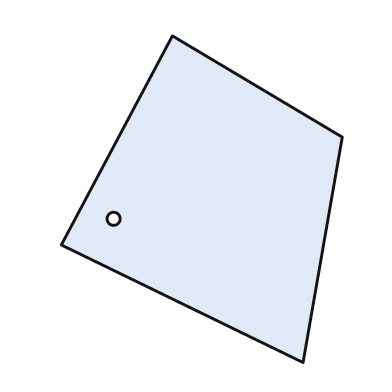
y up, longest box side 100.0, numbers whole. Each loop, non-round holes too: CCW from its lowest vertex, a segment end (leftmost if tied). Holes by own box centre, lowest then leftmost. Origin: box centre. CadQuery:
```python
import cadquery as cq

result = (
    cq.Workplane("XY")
    .moveTo(31.0, -50.0)
    .lineTo(43.0, 19.0)
    .lineTo(-9.0, 50.0)
    .lineTo(-43.0, -14.0)
    .close()
    .moveTo(-27.0, -6.0)
    .circle(2.0)
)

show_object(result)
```